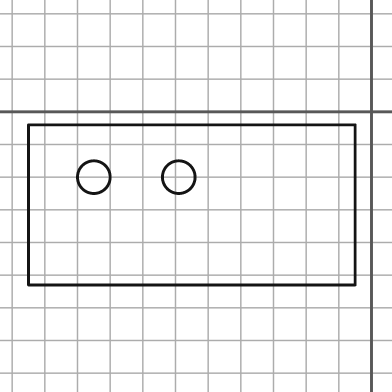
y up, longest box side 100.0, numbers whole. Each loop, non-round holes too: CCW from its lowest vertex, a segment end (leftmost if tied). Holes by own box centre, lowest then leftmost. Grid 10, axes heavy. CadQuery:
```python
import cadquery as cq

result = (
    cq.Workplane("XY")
    .moveTo(-105.0, -53.0)
    .lineTo(-5.0, -53.0)
    .lineTo(-5.0, -4.0)
    .lineTo(-105.0, -4.0)
    .close()
    .moveTo(-85.0, -20.0)
    .circle(5.0)
    .moveTo(-59.0, -20.0)
    .circle(5.0)
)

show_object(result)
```